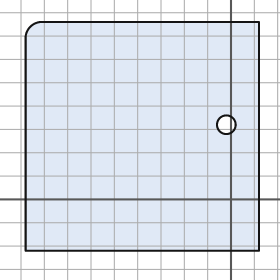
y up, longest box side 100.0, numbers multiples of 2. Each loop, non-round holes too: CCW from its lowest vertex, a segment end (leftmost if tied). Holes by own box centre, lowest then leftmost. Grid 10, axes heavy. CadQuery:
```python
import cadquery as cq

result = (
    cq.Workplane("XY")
    .moveTo(-88.0, -22.0)
    .lineTo(12.0, -22.0)
    .lineTo(12.0, 76.0)
    .lineTo(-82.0, 76.0)
    .threePointArc((-86.0, 74.0), (-88.0, 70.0))
    .close()
    .moveTo(-2.0, 32.0)
    .circle(4.0)
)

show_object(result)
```